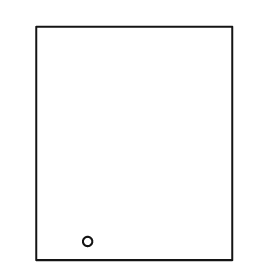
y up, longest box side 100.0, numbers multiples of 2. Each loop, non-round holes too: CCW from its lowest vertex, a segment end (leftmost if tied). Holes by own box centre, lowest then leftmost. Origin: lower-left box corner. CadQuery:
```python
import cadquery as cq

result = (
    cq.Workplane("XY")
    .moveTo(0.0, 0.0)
    .lineTo(84.0, 0.0)
    .lineTo(84.0, 100.0)
    .lineTo(0.0, 100.0)
    .close()
    .moveTo(22.0, 8.0)
    .circle(2.0)
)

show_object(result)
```